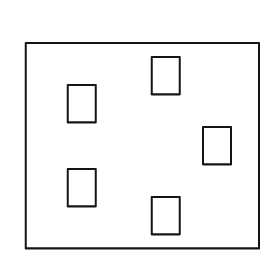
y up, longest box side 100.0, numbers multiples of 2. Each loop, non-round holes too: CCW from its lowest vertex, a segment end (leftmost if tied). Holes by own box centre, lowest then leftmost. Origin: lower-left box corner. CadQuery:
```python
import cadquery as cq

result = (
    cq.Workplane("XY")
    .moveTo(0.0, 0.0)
    .lineTo(100.0, 0.0)
    .lineTo(100.0, 88.0)
    .lineTo(0.0, 88.0)
    .close()
    .moveTo(54.0, 6.0)
    .lineTo(66.0, 6.0)
    .lineTo(66.0, 22.0)
    .lineTo(54.0, 22.0)
    .close()
    .moveTo(18.0, 18.0)
    .lineTo(30.0, 18.0)
    .lineTo(30.0, 34.0)
    .lineTo(18.0, 34.0)
    .close()
    .moveTo(76.0, 36.0)
    .lineTo(88.0, 36.0)
    .lineTo(88.0, 52.0)
    .lineTo(76.0, 52.0)
    .close()
    .moveTo(18.0, 54.0)
    .lineTo(30.0, 54.0)
    .lineTo(30.0, 70.0)
    .lineTo(18.0, 70.0)
    .close()
    .moveTo(54.0, 66.0)
    .lineTo(66.0, 66.0)
    .lineTo(66.0, 82.0)
    .lineTo(54.0, 82.0)
    .close()
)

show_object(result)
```